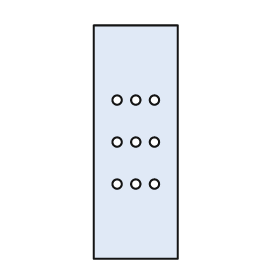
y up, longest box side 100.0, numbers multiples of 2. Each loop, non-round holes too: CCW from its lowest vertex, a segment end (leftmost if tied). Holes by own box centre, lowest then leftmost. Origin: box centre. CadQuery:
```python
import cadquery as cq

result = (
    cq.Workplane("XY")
    .moveTo(-18.0, -50.0)
    .lineTo(18.0, -50.0)
    .lineTo(18.0, 50.0)
    .lineTo(-18.0, 50.0)
    .close()
    .moveTo(-8.0, -18.0)
    .circle(2.0)
    .moveTo(0.0, -18.0)
    .circle(2.0)
    .moveTo(8.0, -18.0)
    .circle(2.0)
    .moveTo(-8.0, 0.0)
    .circle(2.0)
    .moveTo(0.0, 0.0)
    .circle(2.0)
    .moveTo(8.0, 0.0)
    .circle(2.0)
    .moveTo(-8.0, 18.0)
    .circle(2.0)
    .moveTo(0.0, 18.0)
    .circle(2.0)
    .moveTo(8.0, 18.0)
    .circle(2.0)
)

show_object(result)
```